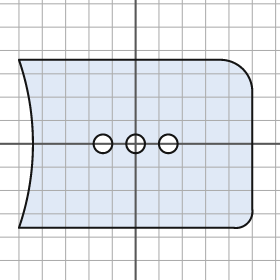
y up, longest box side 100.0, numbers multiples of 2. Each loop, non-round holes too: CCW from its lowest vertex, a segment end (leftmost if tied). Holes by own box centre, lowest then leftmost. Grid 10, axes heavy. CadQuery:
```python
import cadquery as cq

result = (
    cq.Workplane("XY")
    .moveTo(-50.0, -36.0)
    .lineTo(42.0, -36.0)
    .threePointArc((48.0, -34.0), (50.0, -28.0))
    .lineTo(50.0, 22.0)
    .threePointArc((46.0, 32.0), (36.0, 36.0))
    .lineTo(-50.0, 36.0)
    .threePointArc((-44.0, 0.0), (-50.0, -36.0))
    .close()
    .moveTo(-14.0, 0.0)
    .circle(4.0)
    .moveTo(0.0, 0.0)
    .circle(4.0)
    .moveTo(14.0, 0.0)
    .circle(4.0)
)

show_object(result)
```